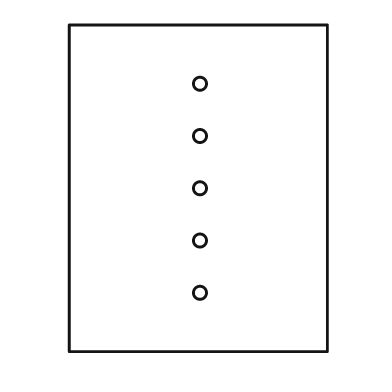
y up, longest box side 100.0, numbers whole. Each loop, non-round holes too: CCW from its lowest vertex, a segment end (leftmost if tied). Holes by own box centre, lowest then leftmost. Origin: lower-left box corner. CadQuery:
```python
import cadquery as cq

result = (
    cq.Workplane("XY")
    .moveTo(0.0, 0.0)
    .lineTo(79.0, 0.0)
    .lineTo(79.0, 100.0)
    .lineTo(0.0, 100.0)
    .close()
    .moveTo(40.0, 18.0)
    .circle(2.0)
    .moveTo(40.0, 34.0)
    .circle(2.0)
    .moveTo(40.0, 50.0)
    .circle(2.0)
    .moveTo(40.0, 66.0)
    .circle(2.0)
    .moveTo(40.0, 82.0)
    .circle(2.0)
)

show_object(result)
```